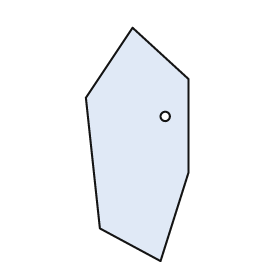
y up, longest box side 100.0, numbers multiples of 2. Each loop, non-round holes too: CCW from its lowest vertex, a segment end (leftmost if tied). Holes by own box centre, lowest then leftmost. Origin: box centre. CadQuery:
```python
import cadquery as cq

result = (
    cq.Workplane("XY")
    .moveTo(10.0, -50.0)
    .lineTo(22.0, -12.0)
    .lineTo(22.0, 28.0)
    .lineTo(-2.0, 50.0)
    .lineTo(-22.0, 20.0)
    .lineTo(-16.0, -36.0)
    .close()
    .moveTo(12.0, 12.0)
    .circle(2.0)
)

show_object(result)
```